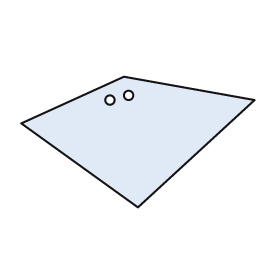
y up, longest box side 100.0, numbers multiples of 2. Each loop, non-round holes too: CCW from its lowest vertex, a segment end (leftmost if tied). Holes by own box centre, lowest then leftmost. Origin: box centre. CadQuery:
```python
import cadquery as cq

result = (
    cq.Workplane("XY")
    .moveTo(0.0, -28.0)
    .lineTo(50.0, 18.0)
    .lineTo(-6.0, 28.0)
    .lineTo(-50.0, 8.0)
    .close()
    .moveTo(-12.0, 18.0)
    .circle(2.0)
    .moveTo(-4.0, 20.0)
    .circle(2.0)
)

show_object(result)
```